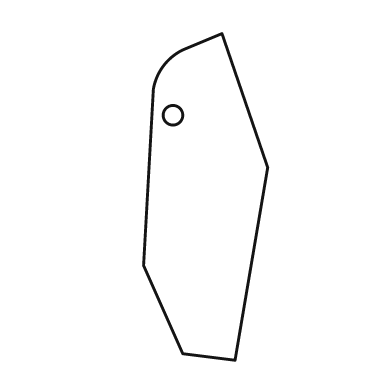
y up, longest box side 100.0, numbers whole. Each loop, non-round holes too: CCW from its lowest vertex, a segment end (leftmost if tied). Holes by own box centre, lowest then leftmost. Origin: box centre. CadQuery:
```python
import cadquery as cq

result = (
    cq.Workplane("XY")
    .moveTo(9.0, -50.0)
    .lineTo(19.0, 9.0)
    .lineTo(5.0, 50.0)
    .lineTo(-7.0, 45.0)
    .threePointArc((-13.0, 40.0), (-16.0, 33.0))
    .lineTo(-19.0, -21.0)
    .lineTo(-7.0, -48.0)
    .close()
    .moveTo(-10.0, 25.0)
    .circle(3.0)
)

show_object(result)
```